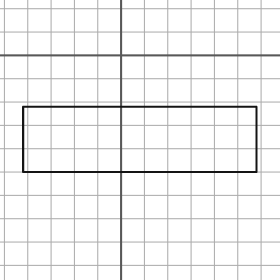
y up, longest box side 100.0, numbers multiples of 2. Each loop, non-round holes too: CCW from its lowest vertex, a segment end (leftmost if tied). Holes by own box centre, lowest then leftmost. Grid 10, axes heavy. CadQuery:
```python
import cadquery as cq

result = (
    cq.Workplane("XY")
    .moveTo(-42.0, -50.0)
    .lineTo(58.0, -50.0)
    .lineTo(58.0, -22.0)
    .lineTo(-42.0, -22.0)
    .close()
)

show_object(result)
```